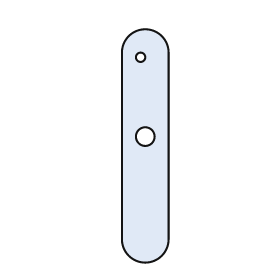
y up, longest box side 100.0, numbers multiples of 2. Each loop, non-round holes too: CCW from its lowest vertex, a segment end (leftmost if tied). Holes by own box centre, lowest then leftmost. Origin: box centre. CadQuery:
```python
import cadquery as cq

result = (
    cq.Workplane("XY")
    .moveTo(-10.0, -40.0)
    .threePointArc((0.0, -50.0), (10.0, -40.0))
    .lineTo(10.0, 40.0)
    .threePointArc((0.0, 50.0), (-10.0, 40.0))
    .close()
    .moveTo(0.0, 4.0)
    .circle(4.0)
    .moveTo(-2.0, 38.0)
    .circle(2.0)
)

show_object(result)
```